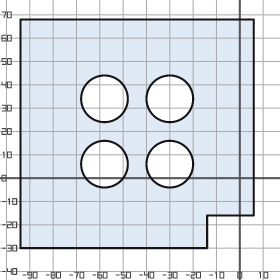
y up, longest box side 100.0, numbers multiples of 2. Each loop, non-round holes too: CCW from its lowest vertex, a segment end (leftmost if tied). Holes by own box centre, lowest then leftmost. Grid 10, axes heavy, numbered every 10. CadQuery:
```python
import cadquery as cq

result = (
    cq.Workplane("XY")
    .moveTo(-94.0, -30.0)
    .lineTo(-14.0, -30.0)
    .lineTo(-14.0, -16.0)
    .lineTo(6.0, -16.0)
    .lineTo(6.0, 68.0)
    .lineTo(-94.0, 68.0)
    .close()
    .moveTo(-58.0, 6.0)
    .circle(10.0)
    .moveTo(-30.0, 6.0)
    .circle(10.0)
    .moveTo(-58.0, 34.0)
    .circle(10.0)
    .moveTo(-30.0, 34.0)
    .circle(10.0)
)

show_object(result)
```